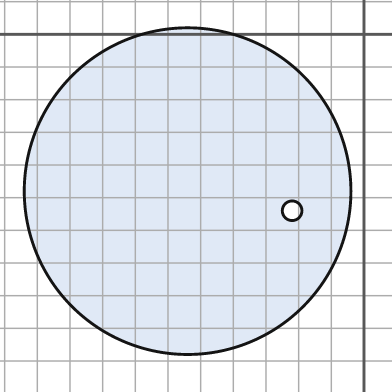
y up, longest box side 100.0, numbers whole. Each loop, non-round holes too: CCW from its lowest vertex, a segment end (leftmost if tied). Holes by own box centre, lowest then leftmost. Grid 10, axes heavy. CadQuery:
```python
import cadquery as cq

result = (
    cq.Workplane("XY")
    .moveTo(-54.0, -48.0)
    .circle(50.0)
    .moveTo(-22.0, -54.0)
    .circle(3.0)
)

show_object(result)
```